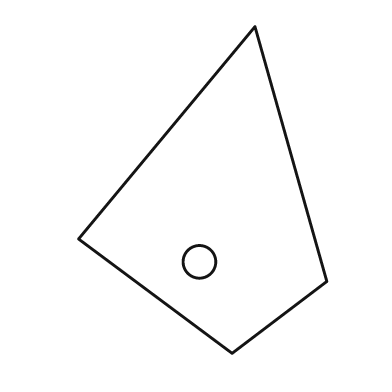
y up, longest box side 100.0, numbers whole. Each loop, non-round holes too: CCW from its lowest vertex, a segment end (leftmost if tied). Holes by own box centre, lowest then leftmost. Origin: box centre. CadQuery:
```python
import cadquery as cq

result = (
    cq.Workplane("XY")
    .moveTo(9.0, -50.0)
    .lineTo(38.0, -28.0)
    .lineTo(16.0, 50.0)
    .lineTo(-38.0, -15.0)
    .close()
    .moveTo(-1.0, -22.0)
    .circle(5.0)
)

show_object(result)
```